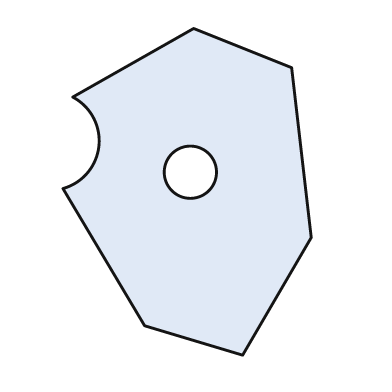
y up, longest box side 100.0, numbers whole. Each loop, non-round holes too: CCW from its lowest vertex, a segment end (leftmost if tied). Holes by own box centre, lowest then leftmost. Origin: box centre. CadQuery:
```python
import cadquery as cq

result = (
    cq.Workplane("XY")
    .moveTo(17.0, -50.0)
    .lineTo(38.0, -14.0)
    .lineTo(32.0, 38.0)
    .lineTo(2.0, 50.0)
    .lineTo(-35.0, 29.0)
    .threePointArc((-27.0, 14.0), (-38.0, 1.0))
    .lineTo(-13.0, -41.0)
    .close()
    .moveTo(1.0, 6.0)
    .circle(8.0)
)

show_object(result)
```